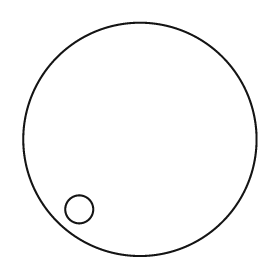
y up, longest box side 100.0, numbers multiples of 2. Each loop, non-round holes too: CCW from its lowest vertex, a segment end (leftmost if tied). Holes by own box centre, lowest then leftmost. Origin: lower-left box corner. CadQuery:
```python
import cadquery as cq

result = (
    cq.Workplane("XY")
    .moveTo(50.0, 50.0)
    .circle(50.0)
    .moveTo(24.0, 20.0)
    .circle(6.0)
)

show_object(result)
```